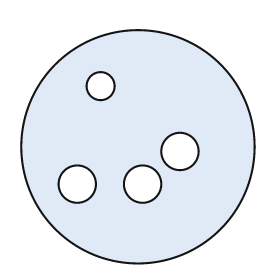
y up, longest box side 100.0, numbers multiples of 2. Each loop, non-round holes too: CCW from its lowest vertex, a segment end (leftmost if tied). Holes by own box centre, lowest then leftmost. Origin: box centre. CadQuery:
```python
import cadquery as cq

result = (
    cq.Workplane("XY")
    .moveTo(0.0, 0.0)
    .circle(50.0)
    .moveTo(-26.0, -16.0)
    .circle(8.0)
    .moveTo(2.0, -16.0)
    .circle(8.0)
    .moveTo(18.0, -2.0)
    .circle(8.0)
    .moveTo(-16.0, 26.0)
    .circle(6.0)
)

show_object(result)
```